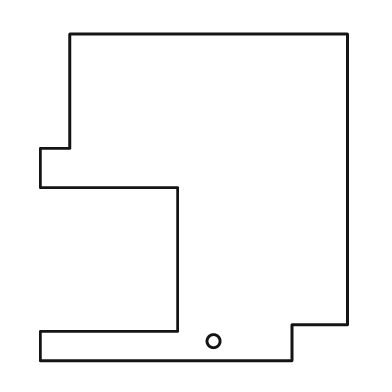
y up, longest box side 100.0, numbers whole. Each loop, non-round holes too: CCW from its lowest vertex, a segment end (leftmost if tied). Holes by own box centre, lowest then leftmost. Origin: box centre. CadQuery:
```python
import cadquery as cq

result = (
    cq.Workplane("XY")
    .moveTo(-47.0, -50.0)
    .lineTo(30.0, -50.0)
    .lineTo(30.0, -39.0)
    .lineTo(47.0, -39.0)
    .lineTo(47.0, 50.0)
    .lineTo(-38.0, 50.0)
    .lineTo(-38.0, 15.0)
    .lineTo(-47.0, 15.0)
    .lineTo(-47.0, 3.0)
    .lineTo(-5.0, 3.0)
    .lineTo(-5.0, -41.0)
    .lineTo(-47.0, -41.0)
    .close()
    .moveTo(6.0, -44.0)
    .circle(2.0)
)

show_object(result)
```